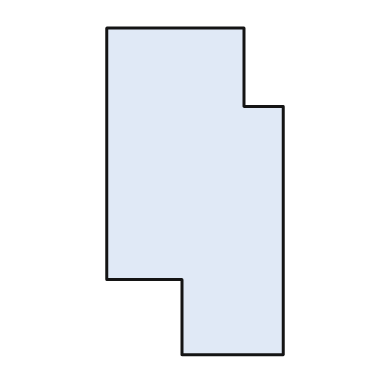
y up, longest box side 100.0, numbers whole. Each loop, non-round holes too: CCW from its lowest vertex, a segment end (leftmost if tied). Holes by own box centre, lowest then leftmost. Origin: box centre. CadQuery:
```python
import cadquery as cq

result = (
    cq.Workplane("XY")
    .moveTo(-4.0, -50.0)
    .lineTo(27.0, -50.0)
    .lineTo(27.0, 26.0)
    .lineTo(15.0, 26.0)
    .lineTo(15.0, 50.0)
    .lineTo(-27.0, 50.0)
    .lineTo(-27.0, -27.0)
    .lineTo(-4.0, -27.0)
    .close()
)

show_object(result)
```